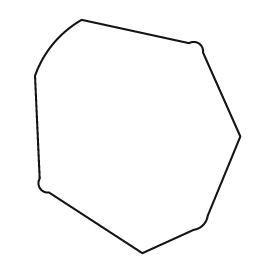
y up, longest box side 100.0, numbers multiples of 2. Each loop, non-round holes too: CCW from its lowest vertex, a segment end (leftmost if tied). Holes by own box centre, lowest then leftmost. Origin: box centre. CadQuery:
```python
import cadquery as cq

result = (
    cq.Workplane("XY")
    .moveTo(2.0, -50.0)
    .lineTo(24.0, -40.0)
    .threePointArc((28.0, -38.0), (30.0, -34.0))
    .lineTo(44.0, 0.0)
    .lineTo(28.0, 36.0)
    .threePointArc((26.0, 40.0), (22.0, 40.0))
    .lineTo(-24.0, 50.0)
    .threePointArc((-36.0, 40.0), (-44.0, 26.0))
    .lineTo(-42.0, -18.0)
    .threePointArc((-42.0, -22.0), (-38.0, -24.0))
    .close()
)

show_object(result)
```